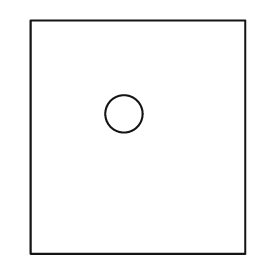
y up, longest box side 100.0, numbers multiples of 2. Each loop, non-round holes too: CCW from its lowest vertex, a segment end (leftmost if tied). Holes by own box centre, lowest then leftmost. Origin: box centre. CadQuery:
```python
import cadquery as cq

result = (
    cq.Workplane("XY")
    .moveTo(-46.0, -50.0)
    .lineTo(46.0, -50.0)
    .lineTo(46.0, 50.0)
    .lineTo(-46.0, 50.0)
    .close()
    .moveTo(-6.0, 10.0)
    .circle(8.0)
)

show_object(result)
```